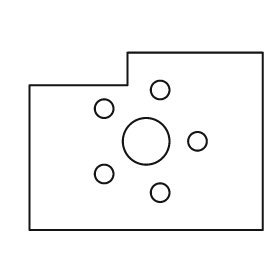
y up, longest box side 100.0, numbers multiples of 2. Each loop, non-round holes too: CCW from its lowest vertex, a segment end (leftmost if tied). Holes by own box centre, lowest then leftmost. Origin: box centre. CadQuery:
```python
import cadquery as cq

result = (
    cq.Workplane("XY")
    .moveTo(-50.0, -38.0)
    .lineTo(50.0, -38.0)
    .lineTo(50.0, 38.0)
    .lineTo(-8.0, 38.0)
    .lineTo(-8.0, 24.0)
    .lineTo(-50.0, 24.0)
    .close()
    .moveTo(6.0, -22.0)
    .circle(4.0)
    .moveTo(-18.0, -14.0)
    .circle(4.0)
    .moveTo(0.0, 0.0)
    .circle(10.0)
    .moveTo(22.0, 0.0)
    .circle(4.0)
    .moveTo(-18.0, 14.0)
    .circle(4.0)
    .moveTo(6.0, 22.0)
    .circle(4.0)
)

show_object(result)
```